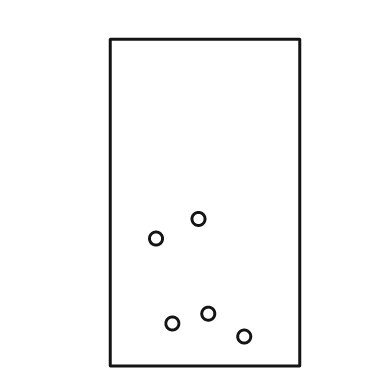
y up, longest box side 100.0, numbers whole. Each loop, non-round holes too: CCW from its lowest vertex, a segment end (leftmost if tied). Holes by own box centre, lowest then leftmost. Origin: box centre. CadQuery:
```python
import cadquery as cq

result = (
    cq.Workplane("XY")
    .moveTo(-29.0, -50.0)
    .lineTo(29.0, -50.0)
    .lineTo(29.0, 50.0)
    .lineTo(-29.0, 50.0)
    .close()
    .moveTo(12.0, -41.0)
    .circle(2.0)
    .moveTo(-10.0, -37.0)
    .circle(2.0)
    .moveTo(1.0, -34.0)
    .circle(2.0)
    .moveTo(-15.0, -11.0)
    .circle(2.0)
    .moveTo(-2.0, -5.0)
    .circle(2.0)
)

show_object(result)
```